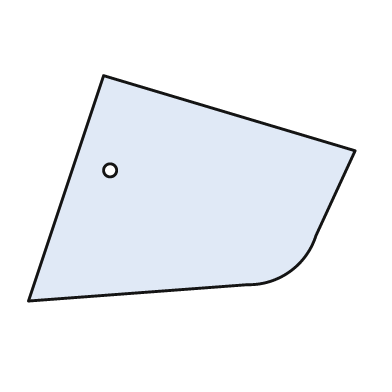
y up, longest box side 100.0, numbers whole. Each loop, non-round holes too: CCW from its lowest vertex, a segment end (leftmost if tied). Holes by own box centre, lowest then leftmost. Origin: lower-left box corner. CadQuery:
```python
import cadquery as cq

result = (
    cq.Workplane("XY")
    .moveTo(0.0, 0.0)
    .lineTo(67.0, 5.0)
    .threePointArc((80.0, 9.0), (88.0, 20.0))
    .lineTo(100.0, 46.0)
    .lineTo(23.0, 69.0)
    .close()
    .moveTo(25.0, 40.0)
    .circle(2.0)
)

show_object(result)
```